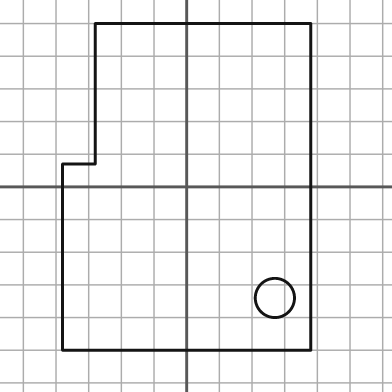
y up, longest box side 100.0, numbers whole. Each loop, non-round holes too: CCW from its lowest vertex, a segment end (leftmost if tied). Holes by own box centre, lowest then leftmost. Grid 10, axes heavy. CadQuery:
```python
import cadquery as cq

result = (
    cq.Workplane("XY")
    .moveTo(-38.0, -50.0)
    .lineTo(38.0, -50.0)
    .lineTo(38.0, 50.0)
    .lineTo(-28.0, 50.0)
    .lineTo(-28.0, 7.0)
    .lineTo(-38.0, 7.0)
    .close()
    .moveTo(27.0, -34.0)
    .circle(6.0)
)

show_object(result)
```